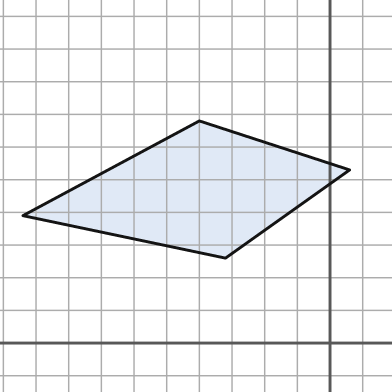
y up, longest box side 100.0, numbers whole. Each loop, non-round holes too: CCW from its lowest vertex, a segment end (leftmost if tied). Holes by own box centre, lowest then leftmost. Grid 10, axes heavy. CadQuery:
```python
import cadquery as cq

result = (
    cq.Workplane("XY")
    .moveTo(-32.0, 26.0)
    .lineTo(6.0, 53.0)
    .lineTo(-40.0, 68.0)
    .lineTo(-94.0, 39.0)
    .close()
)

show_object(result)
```